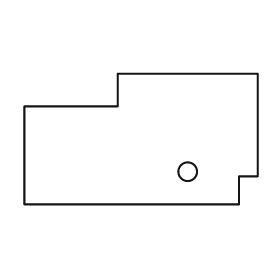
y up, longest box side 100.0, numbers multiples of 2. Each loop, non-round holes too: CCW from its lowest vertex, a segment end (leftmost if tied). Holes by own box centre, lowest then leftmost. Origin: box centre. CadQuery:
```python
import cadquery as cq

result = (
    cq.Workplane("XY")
    .moveTo(-50.0, -28.0)
    .lineTo(42.0, -28.0)
    .lineTo(42.0, -16.0)
    .lineTo(50.0, -16.0)
    .lineTo(50.0, 28.0)
    .lineTo(-10.0, 28.0)
    .lineTo(-10.0, 14.0)
    .lineTo(-50.0, 14.0)
    .close()
    .moveTo(20.0, -14.0)
    .circle(4.0)
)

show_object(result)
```